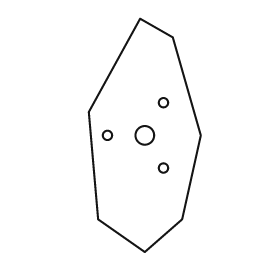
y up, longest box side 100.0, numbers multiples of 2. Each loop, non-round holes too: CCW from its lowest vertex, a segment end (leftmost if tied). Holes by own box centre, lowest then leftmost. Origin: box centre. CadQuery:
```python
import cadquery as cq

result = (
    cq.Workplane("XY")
    .moveTo(0.0, -50.0)
    .lineTo(16.0, -36.0)
    .lineTo(24.0, 0.0)
    .lineTo(12.0, 42.0)
    .lineTo(-2.0, 50.0)
    .lineTo(-24.0, 10.0)
    .lineTo(-20.0, -36.0)
    .close()
    .moveTo(8.0, -14.0)
    .circle(2.0)
    .moveTo(-16.0, 0.0)
    .circle(2.0)
    .moveTo(0.0, 0.0)
    .circle(4.0)
    .moveTo(8.0, 14.0)
    .circle(2.0)
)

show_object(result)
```